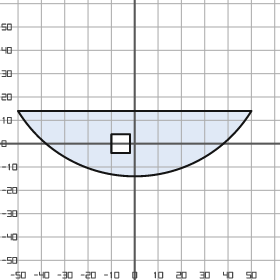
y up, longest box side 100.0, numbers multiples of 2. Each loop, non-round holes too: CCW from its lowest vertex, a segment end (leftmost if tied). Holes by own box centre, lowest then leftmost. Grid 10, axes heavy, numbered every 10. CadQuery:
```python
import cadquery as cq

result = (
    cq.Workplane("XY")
    .moveTo(-50.0, 14.0)
    .threePointArc((0.0, -14.0), (50.0, 14.0))
    .close()
    .moveTo(-10.0, -4.0)
    .lineTo(-2.0, -4.0)
    .lineTo(-2.0, 4.0)
    .lineTo(-10.0, 4.0)
    .close()
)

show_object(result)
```